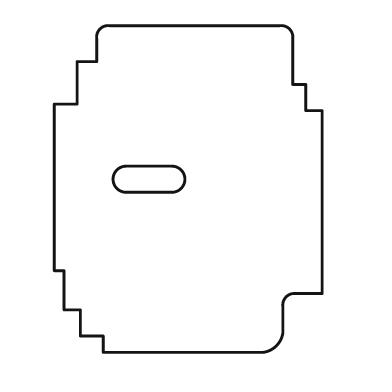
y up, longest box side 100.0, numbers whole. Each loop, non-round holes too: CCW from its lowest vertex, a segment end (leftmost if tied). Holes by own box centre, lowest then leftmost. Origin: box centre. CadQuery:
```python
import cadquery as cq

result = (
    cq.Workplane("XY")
    .moveTo(-26.0, -50.0)
    .lineTo(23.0, -50.0)
    .threePointArc((27.0, -48.0), (29.0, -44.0))
    .lineTo(29.0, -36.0)
    .threePointArc((30.0, -33.0), (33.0, -32.0))
    .lineTo(41.0, -32.0)
    .lineTo(41.0, 24.0)
    .lineTo(36.0, 24.0)
    .lineTo(36.0, 32.0)
    .lineTo(32.0, 32.0)
    .lineTo(32.0, 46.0)
    .threePointArc((31.0, 49.0), (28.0, 50.0))
    .lineTo(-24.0, 50.0)
    .threePointArc((-27.0, 49.0), (-28.0, 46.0))
    .lineTo(-28.0, 39.0)
    .lineTo(-34.0, 39.0)
    .lineTo(-34.0, 26.0)
    .lineTo(-41.0, 26.0)
    .lineTo(-41.0, -25.0)
    .lineTo(-38.0, -25.0)
    .lineTo(-38.0, -37.0)
    .lineTo(-33.0, -37.0)
    .lineTo(-33.0, -45.0)
    .lineTo(-26.0, -45.0)
    .close()
    .moveTo(-19.0, -1.0)
    .lineTo(-5.0, -1.0)
    .threePointArc((-1.0, 3.0), (-5.0, 7.0))
    .lineTo(-19.0, 7.0)
    .threePointArc((-23.0, 3.0), (-19.0, -1.0))
    .close()
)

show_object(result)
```